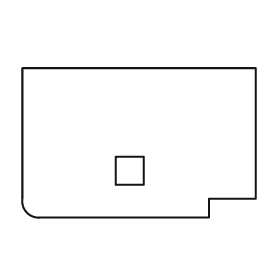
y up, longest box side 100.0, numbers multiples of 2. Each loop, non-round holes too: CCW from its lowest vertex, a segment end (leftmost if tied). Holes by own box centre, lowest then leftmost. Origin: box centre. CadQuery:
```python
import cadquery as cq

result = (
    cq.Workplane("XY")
    .moveTo(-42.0, -32.0)
    .lineTo(30.0, -32.0)
    .lineTo(30.0, -24.0)
    .lineTo(50.0, -24.0)
    .lineTo(50.0, 32.0)
    .lineTo(-50.0, 32.0)
    .lineTo(-50.0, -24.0)
    .threePointArc((-48.0, -30.0), (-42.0, -32.0))
    .close()
    .moveTo(-10.0, -18.0)
    .lineTo(2.0, -18.0)
    .lineTo(2.0, -6.0)
    .lineTo(-10.0, -6.0)
    .close()
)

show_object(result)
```